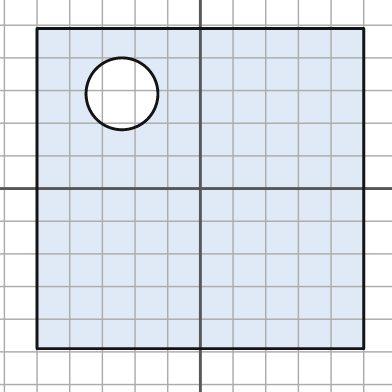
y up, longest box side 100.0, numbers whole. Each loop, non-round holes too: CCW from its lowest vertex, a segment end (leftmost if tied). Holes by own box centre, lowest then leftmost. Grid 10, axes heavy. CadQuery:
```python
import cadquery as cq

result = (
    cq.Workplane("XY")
    .moveTo(-50.0, -49.0)
    .lineTo(50.0, -49.0)
    .lineTo(50.0, 49.0)
    .lineTo(-50.0, 49.0)
    .close()
    .moveTo(-24.0, 29.0)
    .circle(11.0)
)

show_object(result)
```